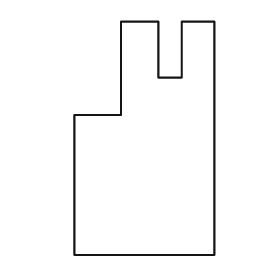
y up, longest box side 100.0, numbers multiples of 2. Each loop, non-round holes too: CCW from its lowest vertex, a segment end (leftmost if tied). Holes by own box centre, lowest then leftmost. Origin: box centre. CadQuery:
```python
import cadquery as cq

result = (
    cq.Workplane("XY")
    .moveTo(-30.0, -50.0)
    .lineTo(30.0, -50.0)
    .lineTo(30.0, 50.0)
    .lineTo(16.0, 50.0)
    .lineTo(16.0, 26.0)
    .lineTo(6.0, 26.0)
    .lineTo(6.0, 50.0)
    .lineTo(-10.0, 50.0)
    .lineTo(-10.0, 10.0)
    .lineTo(-30.0, 10.0)
    .close()
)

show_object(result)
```